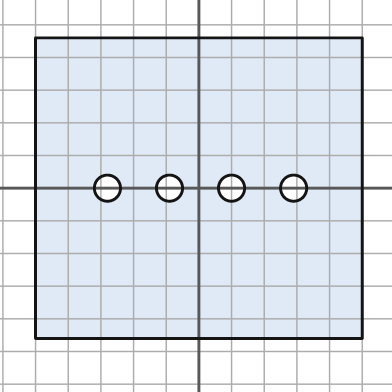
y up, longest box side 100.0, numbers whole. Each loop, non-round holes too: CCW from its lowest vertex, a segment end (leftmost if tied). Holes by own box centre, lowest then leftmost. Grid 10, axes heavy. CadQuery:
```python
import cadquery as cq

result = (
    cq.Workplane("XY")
    .moveTo(-50.0, -46.0)
    .lineTo(50.0, -46.0)
    .lineTo(50.0, 46.0)
    .lineTo(-50.0, 46.0)
    .close()
    .moveTo(-28.0, 0.0)
    .circle(4.0)
    .moveTo(-9.0, 0.0)
    .circle(4.0)
    .moveTo(10.0, 0.0)
    .circle(4.0)
    .moveTo(29.0, 0.0)
    .circle(4.0)
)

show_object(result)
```